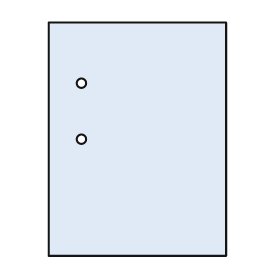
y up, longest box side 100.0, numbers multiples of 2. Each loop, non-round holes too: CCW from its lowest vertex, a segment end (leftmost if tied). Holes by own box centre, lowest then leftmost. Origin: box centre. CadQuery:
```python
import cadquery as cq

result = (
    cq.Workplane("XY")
    .moveTo(-38.0, -50.0)
    .lineTo(38.0, -50.0)
    .lineTo(38.0, 50.0)
    .lineTo(-38.0, 50.0)
    .close()
    .moveTo(-24.0, 0.0)
    .circle(2.0)
    .moveTo(-24.0, 24.0)
    .circle(2.0)
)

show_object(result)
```